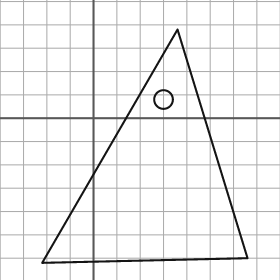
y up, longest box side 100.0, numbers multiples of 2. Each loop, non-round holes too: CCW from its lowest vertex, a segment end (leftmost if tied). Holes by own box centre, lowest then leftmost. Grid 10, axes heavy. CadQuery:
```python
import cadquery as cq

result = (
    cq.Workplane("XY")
    .moveTo(-22.0, -62.0)
    .lineTo(66.0, -60.0)
    .lineTo(36.0, 38.0)
    .close()
    .moveTo(30.0, 8.0)
    .circle(4.0)
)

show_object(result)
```